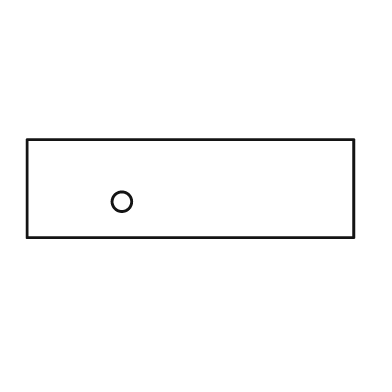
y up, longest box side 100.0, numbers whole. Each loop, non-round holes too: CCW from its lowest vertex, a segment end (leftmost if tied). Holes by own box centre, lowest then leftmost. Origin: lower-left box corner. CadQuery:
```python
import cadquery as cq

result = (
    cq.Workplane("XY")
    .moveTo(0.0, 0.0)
    .lineTo(100.0, 0.0)
    .lineTo(100.0, 30.0)
    .lineTo(0.0, 30.0)
    .close()
    .moveTo(29.0, 11.0)
    .circle(3.0)
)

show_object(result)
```